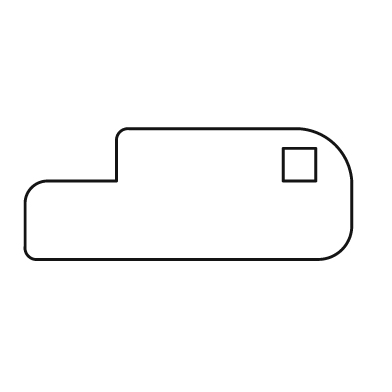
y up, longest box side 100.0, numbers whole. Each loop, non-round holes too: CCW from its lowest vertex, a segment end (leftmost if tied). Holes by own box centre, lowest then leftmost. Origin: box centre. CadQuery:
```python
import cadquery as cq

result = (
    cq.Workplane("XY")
    .moveTo(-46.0, -20.0)
    .lineTo(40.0, -20.0)
    .threePointArc((47.0, -17.0), (50.0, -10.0))
    .lineTo(50.0, 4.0)
    .threePointArc((45.0, 15.0), (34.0, 20.0))
    .lineTo(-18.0, 20.0)
    .threePointArc((-21.0, 19.0), (-22.0, 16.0))
    .lineTo(-22.0, 4.0)
    .lineTo(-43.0, 4.0)
    .threePointArc((-48.0, 2.0), (-50.0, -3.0))
    .lineTo(-50.0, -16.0)
    .threePointArc((-49.0, -19.0), (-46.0, -20.0))
    .close()
    .moveTo(29.0, 4.0)
    .lineTo(39.0, 4.0)
    .lineTo(39.0, 14.0)
    .lineTo(29.0, 14.0)
    .close()
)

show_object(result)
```